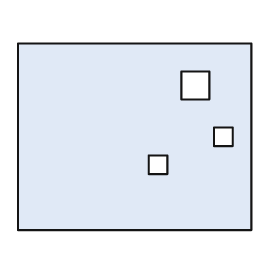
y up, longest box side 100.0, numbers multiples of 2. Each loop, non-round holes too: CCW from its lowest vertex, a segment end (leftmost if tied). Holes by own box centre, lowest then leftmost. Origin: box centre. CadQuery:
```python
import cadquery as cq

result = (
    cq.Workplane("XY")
    .moveTo(-50.0, -40.0)
    .lineTo(50.0, -40.0)
    .lineTo(50.0, 40.0)
    .lineTo(-50.0, 40.0)
    .close()
    .moveTo(6.0, -16.0)
    .lineTo(14.0, -16.0)
    .lineTo(14.0, -8.0)
    .lineTo(6.0, -8.0)
    .close()
    .moveTo(34.0, -4.0)
    .lineTo(42.0, -4.0)
    .lineTo(42.0, 4.0)
    .lineTo(34.0, 4.0)
    .close()
    .moveTo(20.0, 16.0)
    .lineTo(32.0, 16.0)
    .lineTo(32.0, 28.0)
    .lineTo(20.0, 28.0)
    .close()
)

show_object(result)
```